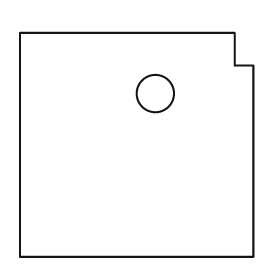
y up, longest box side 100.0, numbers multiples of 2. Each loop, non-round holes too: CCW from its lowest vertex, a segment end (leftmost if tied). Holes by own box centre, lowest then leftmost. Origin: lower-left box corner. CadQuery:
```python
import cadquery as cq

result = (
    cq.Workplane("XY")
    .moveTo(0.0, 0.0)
    .lineTo(100.0, 0.0)
    .lineTo(100.0, 82.0)
    .lineTo(92.0, 82.0)
    .lineTo(92.0, 96.0)
    .lineTo(0.0, 96.0)
    .close()
    .moveTo(58.0, 70.0)
    .circle(8.0)
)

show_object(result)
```